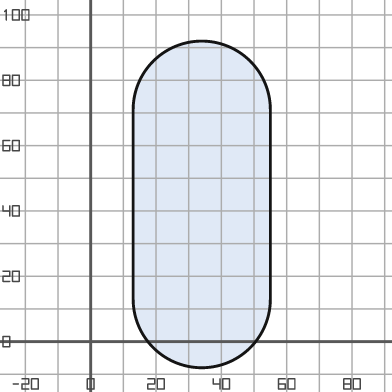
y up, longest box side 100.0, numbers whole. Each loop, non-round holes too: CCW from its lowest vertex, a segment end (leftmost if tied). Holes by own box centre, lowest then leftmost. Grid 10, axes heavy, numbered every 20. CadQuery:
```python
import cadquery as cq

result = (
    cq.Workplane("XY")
    .moveTo(13.0, 13.0)
    .threePointArc((34.0, -8.0), (55.0, 13.0))
    .lineTo(55.0, 71.0)
    .threePointArc((34.0, 92.0), (13.0, 71.0))
    .close()
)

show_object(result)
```